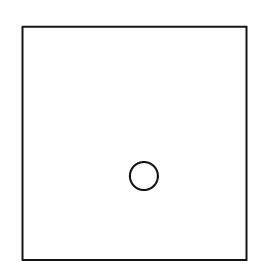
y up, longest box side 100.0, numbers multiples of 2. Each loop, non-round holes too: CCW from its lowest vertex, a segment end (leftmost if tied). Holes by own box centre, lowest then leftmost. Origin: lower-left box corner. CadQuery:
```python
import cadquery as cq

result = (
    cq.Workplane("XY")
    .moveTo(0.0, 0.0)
    .lineTo(96.0, 0.0)
    .lineTo(96.0, 100.0)
    .lineTo(0.0, 100.0)
    .close()
    .moveTo(52.0, 36.0)
    .circle(6.0)
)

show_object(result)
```